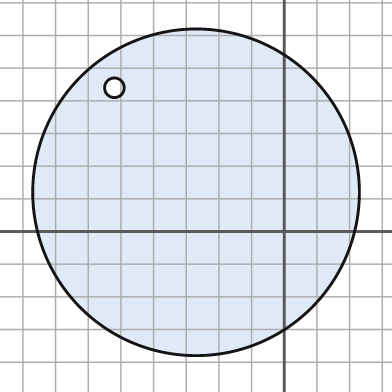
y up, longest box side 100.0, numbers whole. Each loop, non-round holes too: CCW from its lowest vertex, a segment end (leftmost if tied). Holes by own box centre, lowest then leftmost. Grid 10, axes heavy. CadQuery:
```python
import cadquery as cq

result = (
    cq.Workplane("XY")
    .moveTo(-27.0, 12.0)
    .circle(50.0)
    .moveTo(-52.0, 44.0)
    .circle(3.0)
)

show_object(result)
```